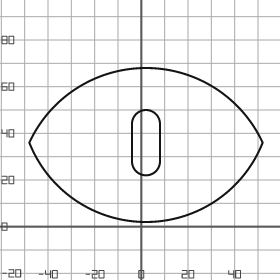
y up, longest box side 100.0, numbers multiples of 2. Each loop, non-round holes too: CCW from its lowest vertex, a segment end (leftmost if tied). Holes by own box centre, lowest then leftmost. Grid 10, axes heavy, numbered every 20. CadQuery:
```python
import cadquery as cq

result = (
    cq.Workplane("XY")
    .moveTo(-48.0, 36.0)
    .threePointArc((2.0, 2.0), (52.0, 36.0))
    .threePointArc((2.0, 68.0), (-48.0, 36.0))
    .close()
    .moveTo(-4.0, 28.0)
    .threePointArc((2.0, 22.0), (8.0, 28.0))
    .lineTo(8.0, 44.0)
    .threePointArc((2.0, 50.0), (-4.0, 44.0))
    .close()
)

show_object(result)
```